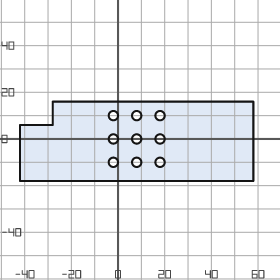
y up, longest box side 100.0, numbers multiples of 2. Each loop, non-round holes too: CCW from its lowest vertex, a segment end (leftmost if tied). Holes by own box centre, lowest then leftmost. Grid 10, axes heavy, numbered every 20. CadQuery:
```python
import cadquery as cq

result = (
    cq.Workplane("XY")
    .moveTo(-42.0, -18.0)
    .lineTo(58.0, -18.0)
    .lineTo(58.0, 16.0)
    .lineTo(-28.0, 16.0)
    .lineTo(-28.0, 6.0)
    .lineTo(-42.0, 6.0)
    .close()
    .moveTo(-2.0, -10.0)
    .circle(2.0)
    .moveTo(8.0, -10.0)
    .circle(2.0)
    .moveTo(18.0, -10.0)
    .circle(2.0)
    .moveTo(-2.0, 0.0)
    .circle(2.0)
    .moveTo(8.0, 0.0)
    .circle(2.0)
    .moveTo(18.0, 0.0)
    .circle(2.0)
    .moveTo(-2.0, 10.0)
    .circle(2.0)
    .moveTo(8.0, 10.0)
    .circle(2.0)
    .moveTo(18.0, 10.0)
    .circle(2.0)
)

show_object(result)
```